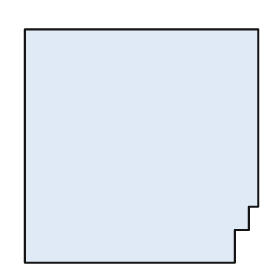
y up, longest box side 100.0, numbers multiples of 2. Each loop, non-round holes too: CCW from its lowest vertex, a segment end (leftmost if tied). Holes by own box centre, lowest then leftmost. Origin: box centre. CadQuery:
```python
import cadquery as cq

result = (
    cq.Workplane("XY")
    .moveTo(-50.0, -50.0)
    .lineTo(40.0, -50.0)
    .lineTo(40.0, -36.0)
    .lineTo(46.0, -36.0)
    .lineTo(46.0, -26.0)
    .lineTo(50.0, -26.0)
    .lineTo(50.0, 50.0)
    .lineTo(-50.0, 50.0)
    .close()
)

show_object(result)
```